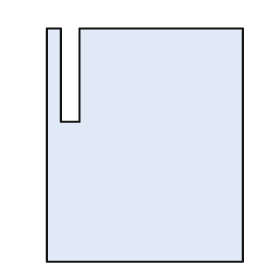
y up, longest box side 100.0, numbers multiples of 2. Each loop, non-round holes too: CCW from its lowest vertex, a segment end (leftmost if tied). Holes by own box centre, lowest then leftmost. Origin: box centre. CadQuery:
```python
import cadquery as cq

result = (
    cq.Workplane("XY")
    .moveTo(-42.0, -50.0)
    .lineTo(42.0, -50.0)
    .lineTo(42.0, 50.0)
    .lineTo(-28.0, 50.0)
    .lineTo(-28.0, 10.0)
    .lineTo(-36.0, 10.0)
    .lineTo(-36.0, 50.0)
    .lineTo(-42.0, 50.0)
    .close()
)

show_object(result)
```